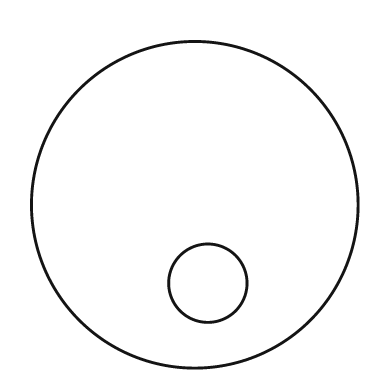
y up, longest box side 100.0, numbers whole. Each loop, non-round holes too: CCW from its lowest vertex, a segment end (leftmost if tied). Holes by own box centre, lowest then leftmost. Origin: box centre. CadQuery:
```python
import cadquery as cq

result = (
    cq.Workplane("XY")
    .moveTo(0.0, 0.0)
    .circle(50.0)
    .moveTo(4.0, -24.0)
    .circle(12.0)
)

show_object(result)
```